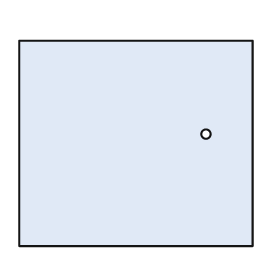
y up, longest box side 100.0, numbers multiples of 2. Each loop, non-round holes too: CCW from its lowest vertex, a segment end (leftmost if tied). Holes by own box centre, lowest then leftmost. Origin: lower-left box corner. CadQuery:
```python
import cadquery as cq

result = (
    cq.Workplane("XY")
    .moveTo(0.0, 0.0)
    .lineTo(100.0, 0.0)
    .lineTo(100.0, 88.0)
    .lineTo(0.0, 88.0)
    .close()
    .moveTo(80.0, 48.0)
    .circle(2.0)
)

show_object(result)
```